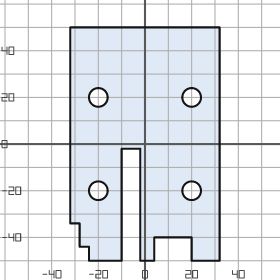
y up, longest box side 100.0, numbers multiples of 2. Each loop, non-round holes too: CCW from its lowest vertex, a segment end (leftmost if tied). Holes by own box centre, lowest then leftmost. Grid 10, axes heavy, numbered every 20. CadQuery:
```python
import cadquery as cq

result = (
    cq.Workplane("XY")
    .moveTo(-24.0, -50.0)
    .lineTo(-10.0, -50.0)
    .lineTo(-10.0, -2.0)
    .lineTo(-2.0, -2.0)
    .lineTo(-2.0, -50.0)
    .lineTo(4.0, -50.0)
    .lineTo(4.0, -40.0)
    .lineTo(20.0, -40.0)
    .lineTo(20.0, -50.0)
    .lineTo(32.0, -50.0)
    .lineTo(32.0, 50.0)
    .lineTo(-32.0, 50.0)
    .lineTo(-32.0, -34.0)
    .lineTo(-28.0, -34.0)
    .lineTo(-28.0, -44.0)
    .lineTo(-24.0, -44.0)
    .close()
    .moveTo(-20.0, -20.0)
    .circle(4.0)
    .moveTo(20.0, -20.0)
    .circle(4.0)
    .moveTo(-20.0, 20.0)
    .circle(4.0)
    .moveTo(20.0, 20.0)
    .circle(4.0)
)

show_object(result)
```